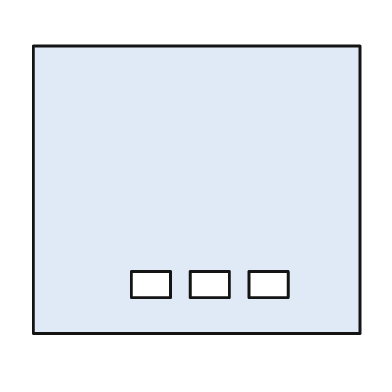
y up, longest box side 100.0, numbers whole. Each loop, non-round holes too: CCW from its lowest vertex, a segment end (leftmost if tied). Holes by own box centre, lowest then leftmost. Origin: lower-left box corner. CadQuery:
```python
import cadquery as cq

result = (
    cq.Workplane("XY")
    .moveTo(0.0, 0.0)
    .lineTo(100.0, 0.0)
    .lineTo(100.0, 88.0)
    .lineTo(0.0, 88.0)
    .close()
    .moveTo(30.0, 11.0)
    .lineTo(42.0, 11.0)
    .lineTo(42.0, 19.0)
    .lineTo(30.0, 19.0)
    .close()
    .moveTo(48.0, 11.0)
    .lineTo(60.0, 11.0)
    .lineTo(60.0, 19.0)
    .lineTo(48.0, 19.0)
    .close()
    .moveTo(66.0, 11.0)
    .lineTo(78.0, 11.0)
    .lineTo(78.0, 19.0)
    .lineTo(66.0, 19.0)
    .close()
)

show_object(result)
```